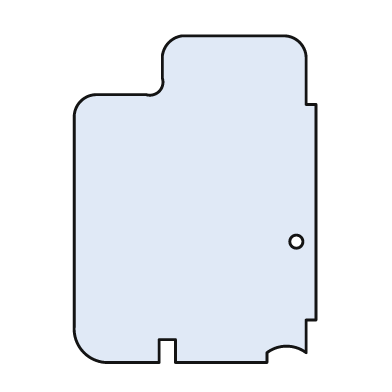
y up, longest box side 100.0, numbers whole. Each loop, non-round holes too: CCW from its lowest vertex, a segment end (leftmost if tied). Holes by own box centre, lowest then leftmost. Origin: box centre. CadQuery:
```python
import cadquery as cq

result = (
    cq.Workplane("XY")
    .moveTo(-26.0, -50.0)
    .lineTo(-11.0, -50.0)
    .lineTo(-11.0, -43.0)
    .lineTo(-6.0, -43.0)
    .lineTo(-6.0, -50.0)
    .lineTo(22.0, -50.0)
    .lineTo(22.0, -47.0)
    .threePointArc((28.0, -45.0), (34.0, -47.0))
    .lineTo(34.0, -37.0)
    .lineTo(37.0, -37.0)
    .lineTo(37.0, 29.0)
    .lineTo(34.0, 29.0)
    .lineTo(34.0, 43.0)
    .threePointArc((32.0, 48.0), (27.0, 50.0))
    .lineTo(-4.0, 50.0)
    .threePointArc((-8.0, 48.0), (-10.0, 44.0))
    .lineTo(-10.0, 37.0)
    .threePointArc((-11.0, 33.0), (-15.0, 32.0))
    .lineTo(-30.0, 32.0)
    .threePointArc((-35.0, 30.0), (-37.0, 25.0))
    .lineTo(-37.0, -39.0)
    .threePointArc((-34.0, -47.0), (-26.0, -50.0))
    .close()
    .moveTo(31.0, -13.0)
    .circle(2.0)
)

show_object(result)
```